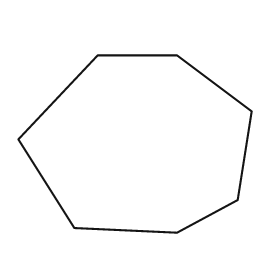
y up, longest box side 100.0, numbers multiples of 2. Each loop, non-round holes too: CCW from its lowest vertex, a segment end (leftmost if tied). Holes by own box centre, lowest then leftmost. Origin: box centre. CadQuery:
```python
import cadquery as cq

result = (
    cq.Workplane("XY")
    .moveTo(18.0, -38.0)
    .lineTo(44.0, -24.0)
    .lineTo(50.0, 14.0)
    .lineTo(18.0, 38.0)
    .lineTo(-16.0, 38.0)
    .lineTo(-50.0, 2.0)
    .lineTo(-26.0, -36.0)
    .close()
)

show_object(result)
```